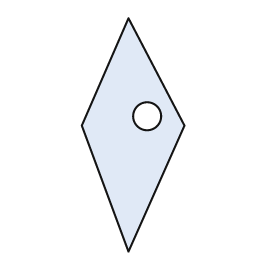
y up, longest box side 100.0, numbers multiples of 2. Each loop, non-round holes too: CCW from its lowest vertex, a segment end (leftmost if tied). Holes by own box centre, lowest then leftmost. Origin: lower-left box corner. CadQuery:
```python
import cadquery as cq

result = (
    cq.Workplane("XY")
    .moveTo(20.0, 0.0)
    .lineTo(44.0, 54.0)
    .lineTo(20.0, 100.0)
    .lineTo(0.0, 54.0)
    .close()
    .moveTo(28.0, 58.0)
    .circle(6.0)
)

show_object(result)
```